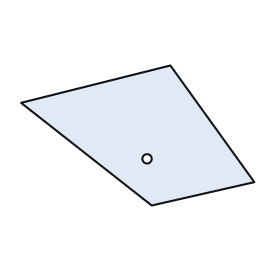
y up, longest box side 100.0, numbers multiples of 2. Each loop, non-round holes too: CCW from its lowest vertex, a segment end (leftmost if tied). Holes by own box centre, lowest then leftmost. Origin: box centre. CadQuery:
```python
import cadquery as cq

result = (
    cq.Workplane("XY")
    .moveTo(6.0, -30.0)
    .lineTo(50.0, -20.0)
    .lineTo(14.0, 30.0)
    .lineTo(-50.0, 14.0)
    .close()
    .moveTo(4.0, -10.0)
    .circle(2.0)
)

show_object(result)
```